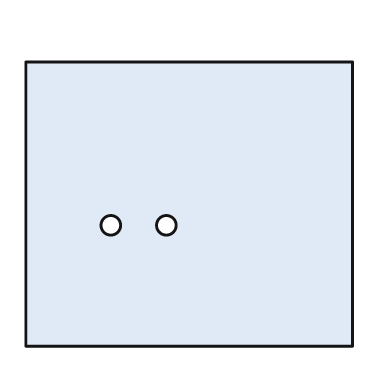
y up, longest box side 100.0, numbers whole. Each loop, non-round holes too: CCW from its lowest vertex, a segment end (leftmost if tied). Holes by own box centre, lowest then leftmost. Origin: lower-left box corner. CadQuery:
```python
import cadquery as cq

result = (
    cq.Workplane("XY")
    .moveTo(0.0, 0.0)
    .lineTo(100.0, 0.0)
    .lineTo(100.0, 87.0)
    .lineTo(0.0, 87.0)
    .close()
    .moveTo(26.0, 37.0)
    .circle(3.0)
    .moveTo(43.0, 37.0)
    .circle(3.0)
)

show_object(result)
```